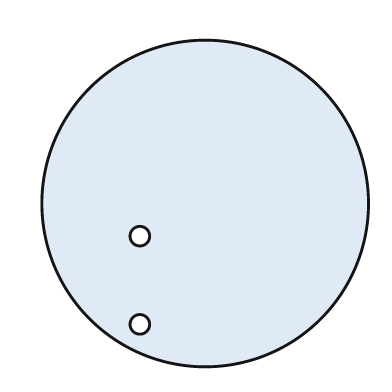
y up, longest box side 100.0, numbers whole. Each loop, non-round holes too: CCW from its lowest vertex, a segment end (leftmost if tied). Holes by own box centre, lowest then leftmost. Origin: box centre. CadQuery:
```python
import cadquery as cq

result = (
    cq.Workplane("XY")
    .moveTo(0.0, 0.0)
    .circle(50.0)
    .moveTo(-20.0, -37.0)
    .circle(3.0)
    .moveTo(-20.0, -10.0)
    .circle(3.0)
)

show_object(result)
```